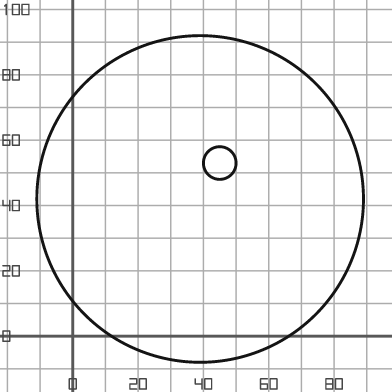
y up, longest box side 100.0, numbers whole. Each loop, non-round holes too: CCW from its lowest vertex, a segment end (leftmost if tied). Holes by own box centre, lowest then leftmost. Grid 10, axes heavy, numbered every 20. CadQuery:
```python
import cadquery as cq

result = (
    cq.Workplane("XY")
    .moveTo(39.0, 42.0)
    .circle(50.0)
    .moveTo(45.0, 53.0)
    .circle(5.0)
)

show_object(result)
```